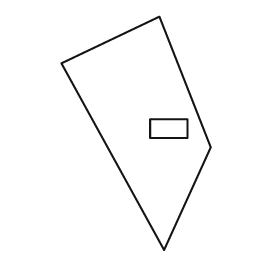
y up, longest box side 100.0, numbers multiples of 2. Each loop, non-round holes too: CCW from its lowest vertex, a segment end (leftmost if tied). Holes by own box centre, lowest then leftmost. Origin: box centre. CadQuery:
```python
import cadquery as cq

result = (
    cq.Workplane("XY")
    .moveTo(12.0, -50.0)
    .lineTo(32.0, -6.0)
    .lineTo(10.0, 50.0)
    .lineTo(-32.0, 30.0)
    .close()
    .moveTo(6.0, -2.0)
    .lineTo(22.0, -2.0)
    .lineTo(22.0, 6.0)
    .lineTo(6.0, 6.0)
    .close()
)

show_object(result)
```